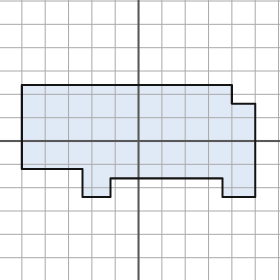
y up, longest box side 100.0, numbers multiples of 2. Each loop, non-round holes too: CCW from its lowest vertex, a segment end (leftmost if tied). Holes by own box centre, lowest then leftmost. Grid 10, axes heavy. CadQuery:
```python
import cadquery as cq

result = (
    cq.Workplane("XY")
    .moveTo(-24.0, -24.0)
    .lineTo(-12.0, -24.0)
    .lineTo(-12.0, -16.0)
    .lineTo(36.0, -16.0)
    .lineTo(36.0, -24.0)
    .lineTo(50.0, -24.0)
    .lineTo(50.0, 16.0)
    .lineTo(40.0, 16.0)
    .lineTo(40.0, 24.0)
    .lineTo(-50.0, 24.0)
    .lineTo(-50.0, -12.0)
    .lineTo(-24.0, -12.0)
    .close()
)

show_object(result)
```